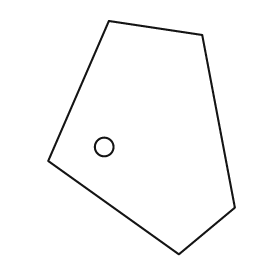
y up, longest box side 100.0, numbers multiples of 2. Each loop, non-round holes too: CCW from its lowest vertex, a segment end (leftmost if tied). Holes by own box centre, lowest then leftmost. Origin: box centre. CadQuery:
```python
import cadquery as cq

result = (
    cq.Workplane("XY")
    .moveTo(16.0, -50.0)
    .lineTo(40.0, -30.0)
    .lineTo(26.0, 44.0)
    .lineTo(-14.0, 50.0)
    .lineTo(-40.0, -10.0)
    .close()
    .moveTo(-16.0, -4.0)
    .circle(4.0)
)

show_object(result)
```